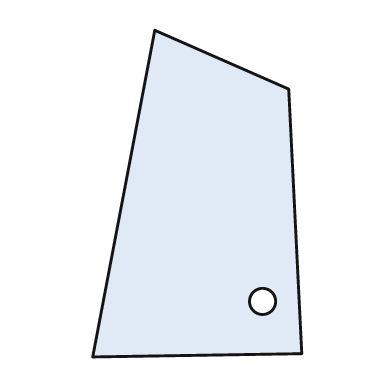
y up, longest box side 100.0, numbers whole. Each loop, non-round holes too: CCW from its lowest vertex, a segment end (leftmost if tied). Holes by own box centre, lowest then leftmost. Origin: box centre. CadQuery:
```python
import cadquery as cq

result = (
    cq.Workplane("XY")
    .moveTo(-32.0, -50.0)
    .lineTo(32.0, -49.0)
    .lineTo(28.0, 32.0)
    .lineTo(-13.0, 50.0)
    .close()
    .moveTo(20.0, -33.0)
    .circle(4.0)
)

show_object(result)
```